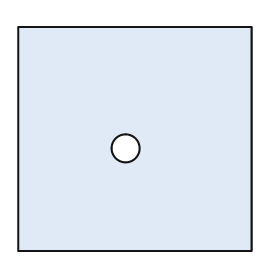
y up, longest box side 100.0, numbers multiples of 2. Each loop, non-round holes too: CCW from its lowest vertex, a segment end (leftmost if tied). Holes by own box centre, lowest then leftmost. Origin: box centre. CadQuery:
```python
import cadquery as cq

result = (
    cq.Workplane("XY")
    .moveTo(-50.0, -48.0)
    .lineTo(50.0, -48.0)
    .lineTo(50.0, 48.0)
    .lineTo(-50.0, 48.0)
    .close()
    .moveTo(-4.0, -4.0)
    .circle(6.0)
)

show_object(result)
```